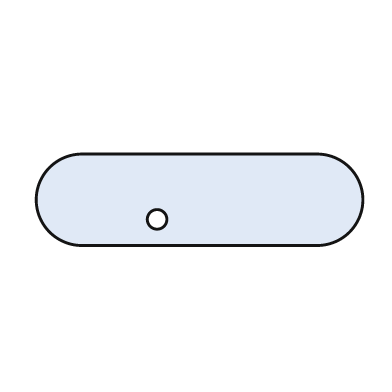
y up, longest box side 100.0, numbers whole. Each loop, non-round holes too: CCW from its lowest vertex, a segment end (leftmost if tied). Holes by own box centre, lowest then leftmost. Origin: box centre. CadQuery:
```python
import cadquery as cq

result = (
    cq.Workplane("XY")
    .moveTo(-36.0, -14.0)
    .lineTo(36.0, -14.0)
    .threePointArc((50.0, 0.0), (36.0, 14.0))
    .lineTo(-36.0, 14.0)
    .threePointArc((-50.0, 0.0), (-36.0, -14.0))
    .close()
    .moveTo(-13.0, -6.0)
    .circle(3.0)
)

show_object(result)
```